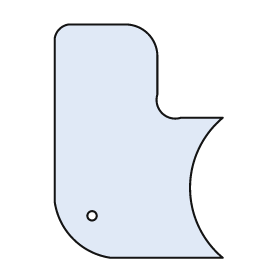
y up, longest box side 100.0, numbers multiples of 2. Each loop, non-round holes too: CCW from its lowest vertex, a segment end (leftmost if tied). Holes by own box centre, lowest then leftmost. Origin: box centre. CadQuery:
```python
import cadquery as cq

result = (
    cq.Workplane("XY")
    .moveTo(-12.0, -50.0)
    .lineTo(36.0, -50.0)
    .threePointArc((22.0, -20.0), (36.0, 10.0))
    .lineTo(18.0, 10.0)
    .threePointArc((10.0, 12.0), (8.0, 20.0))
    .lineTo(8.0, 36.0)
    .threePointArc((4.0, 46.0), (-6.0, 50.0))
    .lineTo(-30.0, 50.0)
    .threePointArc((-34.0, 48.0), (-36.0, 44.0))
    .lineTo(-36.0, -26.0)
    .threePointArc((-28.0, -42.0), (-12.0, -50.0))
    .close()
    .moveTo(-20.0, -32.0)
    .circle(2.0)
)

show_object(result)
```